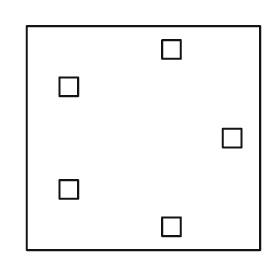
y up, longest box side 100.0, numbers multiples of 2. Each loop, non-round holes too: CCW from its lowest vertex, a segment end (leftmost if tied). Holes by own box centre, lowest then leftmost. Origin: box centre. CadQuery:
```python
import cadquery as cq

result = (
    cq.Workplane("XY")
    .moveTo(-50.0, -48.0)
    .lineTo(50.0, -48.0)
    .lineTo(50.0, 48.0)
    .lineTo(-50.0, 48.0)
    .close()
    .moveTo(8.0, -42.0)
    .lineTo(16.0, -42.0)
    .lineTo(16.0, -34.0)
    .lineTo(8.0, -34.0)
    .close()
    .moveTo(-36.0, -26.0)
    .lineTo(-28.0, -26.0)
    .lineTo(-28.0, -18.0)
    .lineTo(-36.0, -18.0)
    .close()
    .moveTo(34.0, -4.0)
    .lineTo(42.0, -4.0)
    .lineTo(42.0, 4.0)
    .lineTo(34.0, 4.0)
    .close()
    .moveTo(-36.0, 18.0)
    .lineTo(-28.0, 18.0)
    .lineTo(-28.0, 26.0)
    .lineTo(-36.0, 26.0)
    .close()
    .moveTo(8.0, 34.0)
    .lineTo(16.0, 34.0)
    .lineTo(16.0, 42.0)
    .lineTo(8.0, 42.0)
    .close()
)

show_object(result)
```